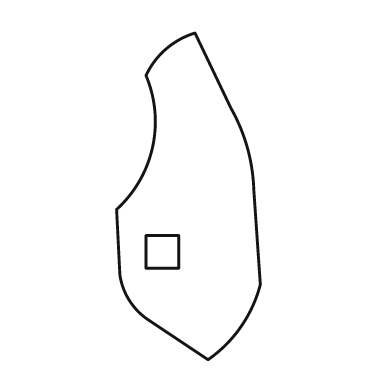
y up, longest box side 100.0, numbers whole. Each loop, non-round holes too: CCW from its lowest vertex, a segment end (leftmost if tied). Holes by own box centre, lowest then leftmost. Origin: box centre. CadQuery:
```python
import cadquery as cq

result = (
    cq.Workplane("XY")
    .moveTo(6.0, -50.0)
    .threePointArc((16.0, -40.0), (22.0, -27.0))
    .lineTo(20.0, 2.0)
    .threePointArc((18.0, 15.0), (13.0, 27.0))
    .lineTo(2.0, 50.0)
    .threePointArc((-7.0, 45.0), (-13.0, 37.0))
    .threePointArc((-11.0, 15.0), (-22.0, -4.0))
    .lineTo(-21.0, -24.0)
    .threePointArc((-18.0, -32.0), (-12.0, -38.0))
    .close()
    .moveTo(-13.0, -22.0)
    .lineTo(-3.0, -22.0)
    .lineTo(-3.0, -12.0)
    .lineTo(-13.0, -12.0)
    .close()
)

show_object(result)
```